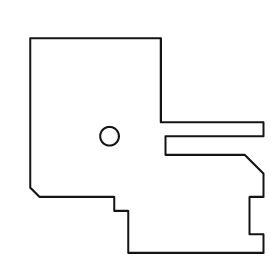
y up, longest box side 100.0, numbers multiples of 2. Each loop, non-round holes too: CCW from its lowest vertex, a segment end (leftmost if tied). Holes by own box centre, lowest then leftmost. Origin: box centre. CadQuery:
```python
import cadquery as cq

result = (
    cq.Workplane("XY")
    .moveTo(-8.0, -46.0)
    .lineTo(50.0, -46.0)
    .lineTo(50.0, -38.0)
    .lineTo(44.0, -38.0)
    .lineTo(44.0, -22.0)
    .lineTo(50.0, -22.0)
    .lineTo(50.0, -12.0)
    .lineTo(42.0, -4.0)
    .lineTo(8.0, -4.0)
    .lineTo(8.0, 4.0)
    .lineTo(50.0, 4.0)
    .lineTo(50.0, 10.0)
    .lineTo(6.0, 10.0)
    .lineTo(6.0, 46.0)
    .lineTo(-50.0, 46.0)
    .lineTo(-50.0, -18.0)
    .lineTo(-46.0, -22.0)
    .lineTo(-14.0, -22.0)
    .lineTo(-14.0, -28.0)
    .lineTo(-8.0, -28.0)
    .close()
    .moveTo(-16.0, 4.0)
    .circle(4.0)
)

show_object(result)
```